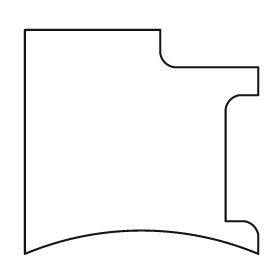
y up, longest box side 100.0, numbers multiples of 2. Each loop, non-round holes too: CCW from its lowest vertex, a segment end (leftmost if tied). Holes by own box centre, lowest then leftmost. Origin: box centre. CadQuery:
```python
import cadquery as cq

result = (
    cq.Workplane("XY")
    .moveTo(-50.0, -48.0)
    .threePointArc((0.0, -38.0), (50.0, -48.0))
    .lineTo(50.0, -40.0)
    .threePointArc((48.0, -36.0), (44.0, -34.0))
    .lineTo(36.0, -34.0)
    .lineTo(36.0, 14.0)
    .threePointArc((38.0, 18.0), (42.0, 20.0))
    .lineTo(50.0, 20.0)
    .lineTo(50.0, 32.0)
    .lineTo(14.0, 32.0)
    .threePointArc((10.0, 34.0), (8.0, 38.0))
    .lineTo(8.0, 48.0)
    .lineTo(-50.0, 48.0)
    .close()
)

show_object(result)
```